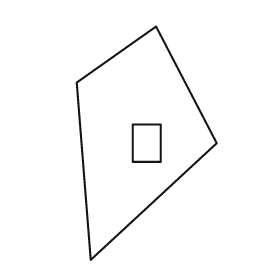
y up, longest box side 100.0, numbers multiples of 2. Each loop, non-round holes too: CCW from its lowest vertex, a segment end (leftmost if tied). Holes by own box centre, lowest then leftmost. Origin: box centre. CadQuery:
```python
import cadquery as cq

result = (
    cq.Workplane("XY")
    .moveTo(-24.0, -50.0)
    .lineTo(30.0, 0.0)
    .lineTo(4.0, 50.0)
    .lineTo(-30.0, 26.0)
    .close()
    .moveTo(-6.0, -8.0)
    .lineTo(6.0, -8.0)
    .lineTo(6.0, 8.0)
    .lineTo(-6.0, 8.0)
    .close()
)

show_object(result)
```